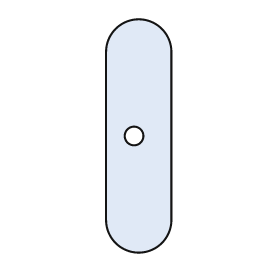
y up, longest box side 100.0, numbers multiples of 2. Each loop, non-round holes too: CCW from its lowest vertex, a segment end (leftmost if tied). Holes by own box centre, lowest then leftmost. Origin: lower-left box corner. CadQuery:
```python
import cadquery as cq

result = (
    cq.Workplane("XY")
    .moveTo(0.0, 14.0)
    .threePointArc((14.0, 0.0), (28.0, 14.0))
    .lineTo(28.0, 86.0)
    .threePointArc((14.0, 100.0), (0.0, 86.0))
    .close()
    .moveTo(12.0, 50.0)
    .circle(4.0)
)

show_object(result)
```